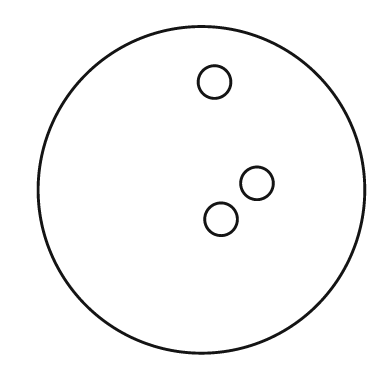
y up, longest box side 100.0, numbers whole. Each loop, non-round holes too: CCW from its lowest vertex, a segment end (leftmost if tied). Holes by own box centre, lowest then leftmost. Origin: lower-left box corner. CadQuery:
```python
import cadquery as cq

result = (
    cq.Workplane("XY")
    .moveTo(50.0, 50.0)
    .circle(50.0)
    .moveTo(56.0, 41.0)
    .circle(5.0)
    .moveTo(67.0, 52.0)
    .circle(5.0)
    .moveTo(54.0, 83.0)
    .circle(5.0)
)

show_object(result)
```